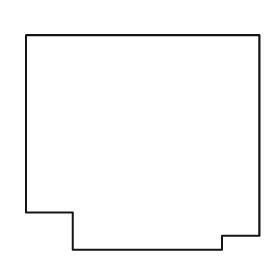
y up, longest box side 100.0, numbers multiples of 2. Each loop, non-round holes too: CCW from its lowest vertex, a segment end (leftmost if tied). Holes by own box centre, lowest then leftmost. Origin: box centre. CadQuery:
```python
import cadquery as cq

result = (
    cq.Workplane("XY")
    .moveTo(-30.0, -46.0)
    .lineTo(34.0, -46.0)
    .lineTo(34.0, -40.0)
    .lineTo(50.0, -40.0)
    .lineTo(50.0, 46.0)
    .lineTo(-50.0, 46.0)
    .lineTo(-50.0, -30.0)
    .lineTo(-30.0, -30.0)
    .close()
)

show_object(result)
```